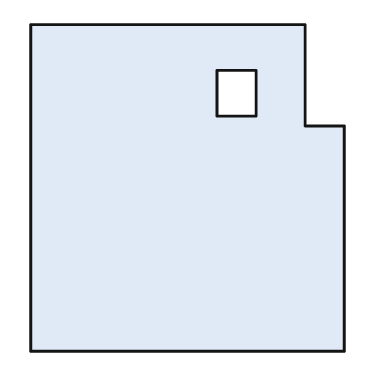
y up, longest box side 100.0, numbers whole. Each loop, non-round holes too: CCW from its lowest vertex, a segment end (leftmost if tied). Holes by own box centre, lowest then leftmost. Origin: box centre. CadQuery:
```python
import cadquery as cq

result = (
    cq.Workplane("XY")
    .moveTo(-48.0, -50.0)
    .lineTo(48.0, -50.0)
    .lineTo(48.0, 19.0)
    .lineTo(36.0, 19.0)
    .lineTo(36.0, 50.0)
    .lineTo(-48.0, 50.0)
    .close()
    .moveTo(9.0, 22.0)
    .lineTo(21.0, 22.0)
    .lineTo(21.0, 36.0)
    .lineTo(9.0, 36.0)
    .close()
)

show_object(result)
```